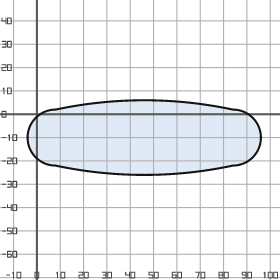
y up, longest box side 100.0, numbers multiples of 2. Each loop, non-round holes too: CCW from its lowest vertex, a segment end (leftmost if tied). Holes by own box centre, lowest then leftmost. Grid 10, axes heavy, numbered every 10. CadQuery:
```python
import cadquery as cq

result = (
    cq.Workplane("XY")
    .moveTo(8.0, -22.0)
    .threePointArc((46.0, -26.0), (84.0, -22.0))
    .threePointArc((96.0, -10.0), (84.0, 2.0))
    .threePointArc((46.0, 6.0), (8.0, 2.0))
    .threePointArc((-4.0, -10.0), (8.0, -22.0))
    .close()
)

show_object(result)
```